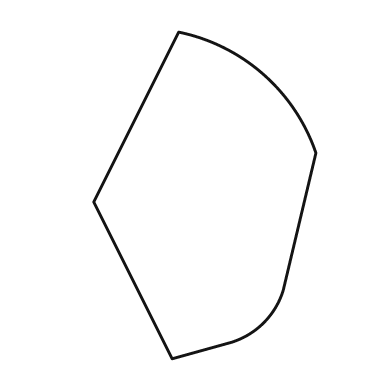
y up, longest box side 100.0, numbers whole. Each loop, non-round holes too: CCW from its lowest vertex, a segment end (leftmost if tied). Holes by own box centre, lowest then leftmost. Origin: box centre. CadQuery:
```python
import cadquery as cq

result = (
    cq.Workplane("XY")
    .moveTo(-10.0, -50.0)
    .lineTo(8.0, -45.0)
    .threePointArc((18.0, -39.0), (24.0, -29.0))
    .lineTo(34.0, 13.0)
    .threePointArc((18.0, 37.0), (-8.0, 50.0))
    .lineTo(-34.0, -2.0)
    .close()
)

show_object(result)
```